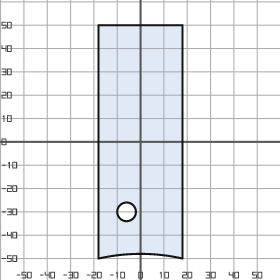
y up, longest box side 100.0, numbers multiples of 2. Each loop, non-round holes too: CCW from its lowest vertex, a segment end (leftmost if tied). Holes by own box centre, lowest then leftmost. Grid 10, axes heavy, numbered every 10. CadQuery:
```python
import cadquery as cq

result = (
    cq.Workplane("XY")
    .moveTo(-18.0, -50.0)
    .threePointArc((0.0, -48.0), (18.0, -50.0))
    .lineTo(18.0, 50.0)
    .lineTo(-18.0, 50.0)
    .close()
    .moveTo(-6.0, -30.0)
    .circle(4.0)
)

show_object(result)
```